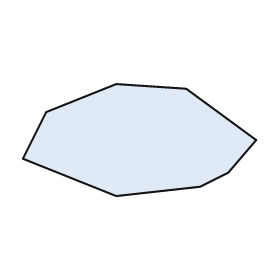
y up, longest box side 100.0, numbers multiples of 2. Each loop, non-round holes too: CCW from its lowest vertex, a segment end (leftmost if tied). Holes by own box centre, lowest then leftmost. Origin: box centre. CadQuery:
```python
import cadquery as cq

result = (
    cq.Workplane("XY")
    .moveTo(-10.0, -24.0)
    .lineTo(26.0, -20.0)
    .lineTo(38.0, -14.0)
    .lineTo(50.0, 0.0)
    .lineTo(20.0, 22.0)
    .lineTo(-10.0, 24.0)
    .lineTo(-40.0, 12.0)
    .lineTo(-50.0, -8.0)
    .close()
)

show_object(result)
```